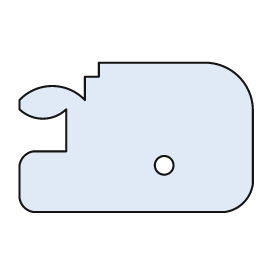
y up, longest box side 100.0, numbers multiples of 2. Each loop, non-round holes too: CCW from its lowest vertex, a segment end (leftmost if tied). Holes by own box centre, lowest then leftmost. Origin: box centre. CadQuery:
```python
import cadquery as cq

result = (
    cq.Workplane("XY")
    .moveTo(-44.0, -32.0)
    .lineTo(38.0, -32.0)
    .threePointArc((46.0, -28.0), (50.0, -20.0))
    .lineTo(50.0, 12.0)
    .threePointArc((44.0, 26.0), (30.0, 32.0))
    .lineTo(-16.0, 32.0)
    .lineTo(-16.0, 26.0)
    .lineTo(-22.0, 26.0)
    .lineTo(-22.0, 16.0)
    .threePointArc((-36.0, 22.0), (-50.0, 16.0))
    .lineTo(-50.0, 12.0)
    .threePointArc((-40.0, 8.0), (-30.0, 12.0))
    .lineTo(-30.0, -6.0)
    .lineTo(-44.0, -6.0)
    .threePointArc((-48.0, -8.0), (-50.0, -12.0))
    .lineTo(-50.0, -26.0)
    .threePointArc((-48.0, -30.0), (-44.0, -32.0))
    .close()
    .moveTo(12.0, -12.0)
    .circle(4.0)
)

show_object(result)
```